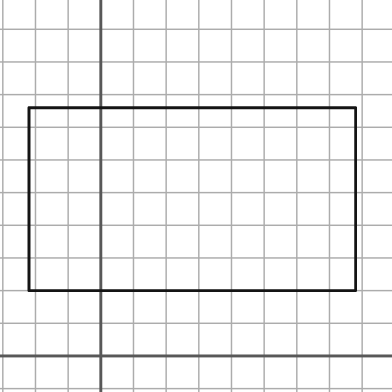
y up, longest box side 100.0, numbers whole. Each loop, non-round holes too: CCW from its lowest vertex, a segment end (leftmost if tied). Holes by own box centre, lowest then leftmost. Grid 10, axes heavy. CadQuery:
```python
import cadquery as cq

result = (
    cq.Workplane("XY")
    .moveTo(-22.0, 20.0)
    .lineTo(78.0, 20.0)
    .lineTo(78.0, 76.0)
    .lineTo(-22.0, 76.0)
    .close()
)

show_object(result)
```